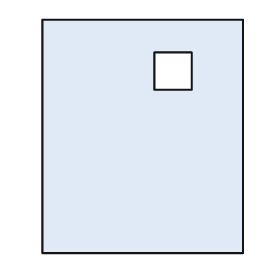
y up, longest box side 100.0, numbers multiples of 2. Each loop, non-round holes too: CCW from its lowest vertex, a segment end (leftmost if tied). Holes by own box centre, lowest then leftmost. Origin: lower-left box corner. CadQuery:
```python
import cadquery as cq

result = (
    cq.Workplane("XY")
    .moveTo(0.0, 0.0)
    .lineTo(86.0, 0.0)
    .lineTo(86.0, 100.0)
    .lineTo(0.0, 100.0)
    .close()
    .moveTo(48.0, 70.0)
    .lineTo(64.0, 70.0)
    .lineTo(64.0, 86.0)
    .lineTo(48.0, 86.0)
    .close()
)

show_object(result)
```